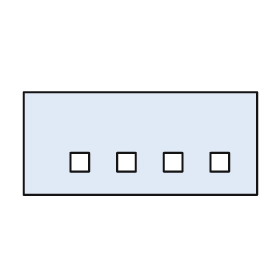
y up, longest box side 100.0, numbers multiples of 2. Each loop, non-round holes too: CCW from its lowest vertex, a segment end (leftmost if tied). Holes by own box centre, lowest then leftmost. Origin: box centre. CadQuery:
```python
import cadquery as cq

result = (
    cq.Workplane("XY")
    .moveTo(-50.0, -22.0)
    .lineTo(50.0, -22.0)
    .lineTo(50.0, 22.0)
    .lineTo(-50.0, 22.0)
    .close()
    .moveTo(-30.0, -12.0)
    .lineTo(-22.0, -12.0)
    .lineTo(-22.0, -4.0)
    .lineTo(-30.0, -4.0)
    .close()
    .moveTo(-10.0, -12.0)
    .lineTo(-2.0, -12.0)
    .lineTo(-2.0, -4.0)
    .lineTo(-10.0, -4.0)
    .close()
    .moveTo(10.0, -12.0)
    .lineTo(18.0, -12.0)
    .lineTo(18.0, -4.0)
    .lineTo(10.0, -4.0)
    .close()
    .moveTo(30.0, -12.0)
    .lineTo(38.0, -12.0)
    .lineTo(38.0, -4.0)
    .lineTo(30.0, -4.0)
    .close()
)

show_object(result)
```